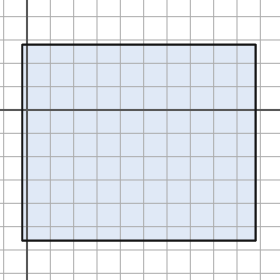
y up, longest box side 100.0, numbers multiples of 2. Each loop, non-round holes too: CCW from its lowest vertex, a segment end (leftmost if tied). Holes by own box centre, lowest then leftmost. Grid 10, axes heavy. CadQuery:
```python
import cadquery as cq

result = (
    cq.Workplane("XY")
    .moveTo(-2.0, -56.0)
    .lineTo(98.0, -56.0)
    .lineTo(98.0, 28.0)
    .lineTo(-2.0, 28.0)
    .close()
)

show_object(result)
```